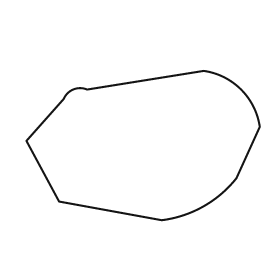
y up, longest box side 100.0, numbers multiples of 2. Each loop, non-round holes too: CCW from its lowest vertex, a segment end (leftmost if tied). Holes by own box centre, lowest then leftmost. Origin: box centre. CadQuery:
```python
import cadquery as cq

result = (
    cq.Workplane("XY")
    .moveTo(8.0, -32.0)
    .threePointArc((26.0, -26.0), (40.0, -14.0))
    .lineTo(50.0, 8.0)
    .threePointArc((42.0, 24.0), (26.0, 32.0))
    .lineTo(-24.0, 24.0)
    .threePointArc((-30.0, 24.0), (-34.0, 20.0))
    .lineTo(-50.0, 2.0)
    .lineTo(-36.0, -24.0)
    .close()
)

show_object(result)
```